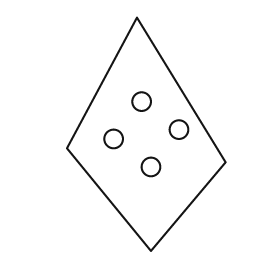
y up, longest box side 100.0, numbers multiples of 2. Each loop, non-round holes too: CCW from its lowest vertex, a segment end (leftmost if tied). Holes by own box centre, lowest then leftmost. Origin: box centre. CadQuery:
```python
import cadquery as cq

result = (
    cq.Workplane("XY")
    .moveTo(2.0, -50.0)
    .lineTo(34.0, -12.0)
    .lineTo(-4.0, 50.0)
    .lineTo(-34.0, -6.0)
    .close()
    .moveTo(2.0, -14.0)
    .circle(4.0)
    .moveTo(-14.0, -2.0)
    .circle(4.0)
    .moveTo(14.0, 2.0)
    .circle(4.0)
    .moveTo(-2.0, 14.0)
    .circle(4.0)
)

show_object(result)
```